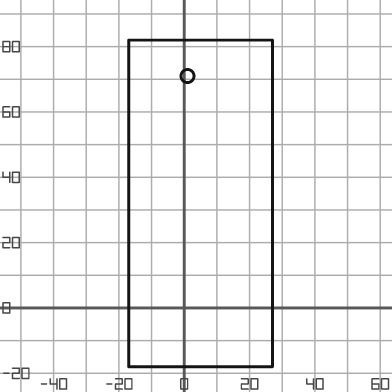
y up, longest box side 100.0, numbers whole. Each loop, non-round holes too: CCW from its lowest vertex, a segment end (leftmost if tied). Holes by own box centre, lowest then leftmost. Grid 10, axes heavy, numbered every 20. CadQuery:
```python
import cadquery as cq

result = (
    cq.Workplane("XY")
    .moveTo(-17.0, -18.0)
    .lineTo(27.0, -18.0)
    .lineTo(27.0, 82.0)
    .lineTo(-17.0, 82.0)
    .close()
    .moveTo(1.0, 71.0)
    .circle(2.0)
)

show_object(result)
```